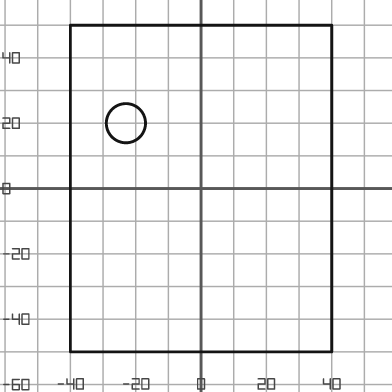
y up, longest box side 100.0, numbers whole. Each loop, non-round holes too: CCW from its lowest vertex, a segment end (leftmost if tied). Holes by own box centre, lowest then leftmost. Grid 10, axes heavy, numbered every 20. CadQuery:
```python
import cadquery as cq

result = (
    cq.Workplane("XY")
    .moveTo(-40.0, -50.0)
    .lineTo(40.0, -50.0)
    .lineTo(40.0, 50.0)
    .lineTo(-40.0, 50.0)
    .close()
    .moveTo(-23.0, 20.0)
    .circle(6.0)
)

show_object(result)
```